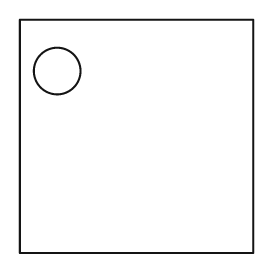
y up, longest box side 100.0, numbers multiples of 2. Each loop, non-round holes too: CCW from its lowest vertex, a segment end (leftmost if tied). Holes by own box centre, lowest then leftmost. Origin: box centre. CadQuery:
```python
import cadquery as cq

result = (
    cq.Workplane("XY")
    .moveTo(-50.0, -50.0)
    .lineTo(50.0, -50.0)
    .lineTo(50.0, 50.0)
    .lineTo(-50.0, 50.0)
    .close()
    .moveTo(-34.0, 28.0)
    .circle(10.0)
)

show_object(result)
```